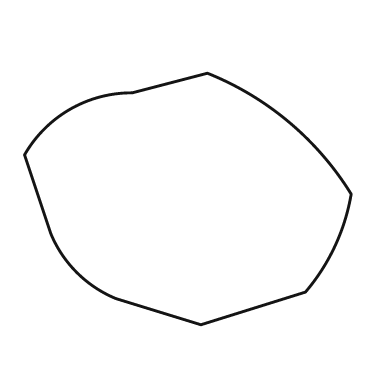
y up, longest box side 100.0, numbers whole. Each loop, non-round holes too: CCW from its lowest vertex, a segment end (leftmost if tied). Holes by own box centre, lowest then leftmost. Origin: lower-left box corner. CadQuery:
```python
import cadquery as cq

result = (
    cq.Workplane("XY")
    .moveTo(54.0, 0.0)
    .lineTo(86.0, 10.0)
    .threePointArc((95.0, 24.0), (100.0, 40.0))
    .threePointArc((81.0, 62.0), (56.0, 77.0))
    .lineTo(33.0, 71.0)
    .threePointArc((14.0, 66.0), (0.0, 52.0))
    .lineTo(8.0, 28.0)
    .threePointArc((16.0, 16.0), (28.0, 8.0))
    .close()
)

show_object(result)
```